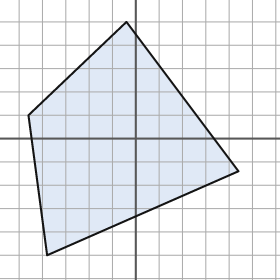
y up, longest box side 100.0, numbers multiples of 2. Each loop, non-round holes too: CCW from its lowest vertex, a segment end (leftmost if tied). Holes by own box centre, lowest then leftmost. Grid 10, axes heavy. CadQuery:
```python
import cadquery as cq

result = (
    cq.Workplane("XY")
    .moveTo(-38.0, -50.0)
    .lineTo(44.0, -14.0)
    .lineTo(-4.0, 50.0)
    .lineTo(-46.0, 10.0)
    .close()
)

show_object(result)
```